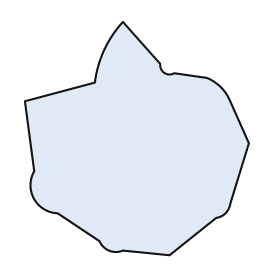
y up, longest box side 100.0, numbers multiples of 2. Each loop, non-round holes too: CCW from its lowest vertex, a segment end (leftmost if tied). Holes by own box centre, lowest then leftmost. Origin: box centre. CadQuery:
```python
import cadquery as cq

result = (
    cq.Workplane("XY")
    .moveTo(14.0, -50.0)
    .lineTo(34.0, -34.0)
    .threePointArc((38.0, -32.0), (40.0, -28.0))
    .lineTo(48.0, -2.0)
    .lineTo(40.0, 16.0)
    .threePointArc((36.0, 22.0), (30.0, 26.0))
    .lineTo(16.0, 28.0)
    .threePointArc((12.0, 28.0), (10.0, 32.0))
    .lineTo(-6.0, 50.0)
    .threePointArc((-14.0, 38.0), (-18.0, 24.0))
    .lineTo(-48.0, 16.0)
    .lineTo(-44.0, -14.0)
    .threePointArc((-44.0, -26.0), (-34.0, -32.0))
    .lineTo(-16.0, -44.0)
    .threePointArc((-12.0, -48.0), (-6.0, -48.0))
    .close()
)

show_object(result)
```